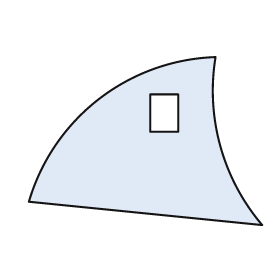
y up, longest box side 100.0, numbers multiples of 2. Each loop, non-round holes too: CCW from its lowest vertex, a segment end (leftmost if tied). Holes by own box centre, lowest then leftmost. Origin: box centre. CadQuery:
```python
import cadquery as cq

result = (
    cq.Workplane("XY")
    .moveTo(50.0, -36.0)
    .threePointArc((32.0, -2.0), (30.0, 36.0))
    .threePointArc((-20.0, 18.0), (-50.0, -26.0))
    .close()
    .moveTo(2.0, 4.0)
    .lineTo(14.0, 4.0)
    .lineTo(14.0, 20.0)
    .lineTo(2.0, 20.0)
    .close()
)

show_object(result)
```